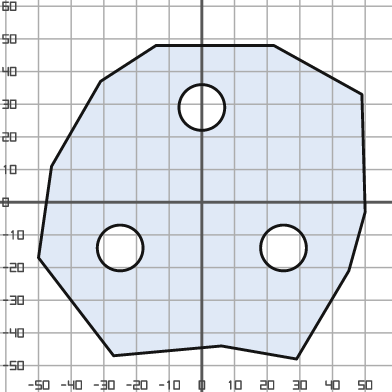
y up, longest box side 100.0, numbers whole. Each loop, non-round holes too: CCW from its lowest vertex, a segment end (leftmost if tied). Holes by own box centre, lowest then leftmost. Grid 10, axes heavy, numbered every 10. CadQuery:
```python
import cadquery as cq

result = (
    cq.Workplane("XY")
    .moveTo(29.0, -48.0)
    .lineTo(45.0, -21.0)
    .lineTo(50.0, -3.0)
    .lineTo(49.0, 33.0)
    .lineTo(22.0, 48.0)
    .lineTo(-14.0, 48.0)
    .lineTo(-31.0, 37.0)
    .lineTo(-46.0, 11.0)
    .lineTo(-50.0, -17.0)
    .lineTo(-27.0, -47.0)
    .lineTo(6.0, -44.0)
    .close()
    .moveTo(-25.0, -14.0)
    .circle(7.0)
    .moveTo(25.0, -14.0)
    .circle(7.0)
    .moveTo(0.0, 29.0)
    .circle(7.0)
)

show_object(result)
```